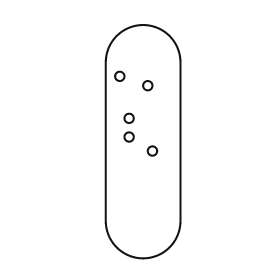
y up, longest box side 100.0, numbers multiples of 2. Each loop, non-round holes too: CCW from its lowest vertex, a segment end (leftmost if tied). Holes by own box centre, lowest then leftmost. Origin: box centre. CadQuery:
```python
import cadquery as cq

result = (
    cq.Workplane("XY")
    .moveTo(-16.0, -34.0)
    .threePointArc((0.0, -50.0), (16.0, -34.0))
    .lineTo(16.0, 34.0)
    .threePointArc((0.0, 50.0), (-16.0, 34.0))
    .close()
    .moveTo(4.0, -4.0)
    .circle(2.0)
    .moveTo(-6.0, 2.0)
    .circle(2.0)
    .moveTo(-6.0, 10.0)
    .circle(2.0)
    .moveTo(2.0, 24.0)
    .circle(2.0)
    .moveTo(-10.0, 28.0)
    .circle(2.0)
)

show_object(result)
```